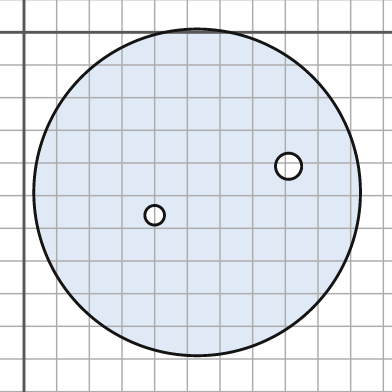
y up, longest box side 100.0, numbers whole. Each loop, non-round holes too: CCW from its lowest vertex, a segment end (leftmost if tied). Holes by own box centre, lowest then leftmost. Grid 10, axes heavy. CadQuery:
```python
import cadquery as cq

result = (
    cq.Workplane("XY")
    .moveTo(53.0, -49.0)
    .circle(50.0)
    .moveTo(40.0, -56.0)
    .circle(3.0)
    .moveTo(81.0, -41.0)
    .circle(4.0)
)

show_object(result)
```